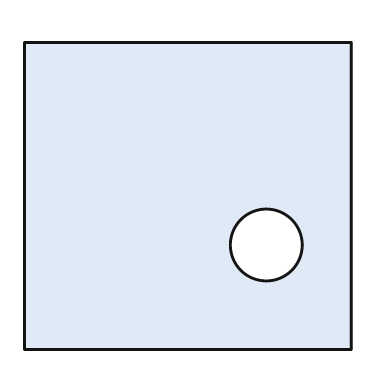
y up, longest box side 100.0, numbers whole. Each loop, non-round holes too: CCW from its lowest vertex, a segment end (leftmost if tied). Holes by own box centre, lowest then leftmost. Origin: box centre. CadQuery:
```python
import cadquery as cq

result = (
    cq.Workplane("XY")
    .moveTo(-50.0, -47.0)
    .lineTo(50.0, -47.0)
    .lineTo(50.0, 47.0)
    .lineTo(-50.0, 47.0)
    .close()
    .moveTo(24.0, -15.0)
    .circle(11.0)
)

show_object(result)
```